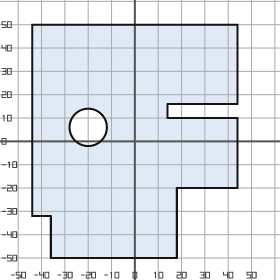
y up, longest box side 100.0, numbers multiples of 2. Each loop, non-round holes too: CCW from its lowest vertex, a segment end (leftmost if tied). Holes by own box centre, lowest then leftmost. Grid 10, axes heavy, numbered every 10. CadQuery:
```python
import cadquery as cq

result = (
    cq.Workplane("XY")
    .moveTo(-36.0, -50.0)
    .lineTo(18.0, -50.0)
    .lineTo(18.0, -20.0)
    .lineTo(44.0, -20.0)
    .lineTo(44.0, 10.0)
    .lineTo(14.0, 10.0)
    .lineTo(14.0, 16.0)
    .lineTo(44.0, 16.0)
    .lineTo(44.0, 50.0)
    .lineTo(-44.0, 50.0)
    .lineTo(-44.0, -32.0)
    .lineTo(-36.0, -32.0)
    .close()
    .moveTo(-20.0, 6.0)
    .circle(8.0)
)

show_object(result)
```